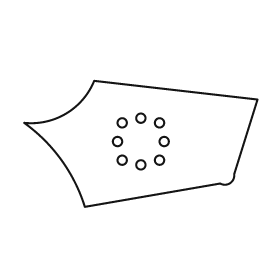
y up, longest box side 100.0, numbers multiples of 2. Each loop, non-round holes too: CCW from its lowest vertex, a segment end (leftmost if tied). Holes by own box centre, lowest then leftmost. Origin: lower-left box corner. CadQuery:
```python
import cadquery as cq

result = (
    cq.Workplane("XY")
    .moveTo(26.0, 0.0)
    .lineTo(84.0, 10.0)
    .threePointArc((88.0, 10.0), (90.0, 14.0))
    .lineTo(100.0, 46.0)
    .lineTo(30.0, 54.0)
    .threePointArc((18.0, 40.0), (0.0, 36.0))
    .threePointArc((16.0, 20.0), (26.0, 0.0))
    .close()
    .moveTo(50.0, 18.0)
    .circle(2.0)
    .moveTo(42.0, 20.0)
    .circle(2.0)
    .moveTo(58.0, 20.0)
    .circle(2.0)
    .moveTo(40.0, 28.0)
    .circle(2.0)
    .moveTo(60.0, 28.0)
    .circle(2.0)
    .moveTo(42.0, 36.0)
    .circle(2.0)
    .moveTo(58.0, 36.0)
    .circle(2.0)
    .moveTo(50.0, 38.0)
    .circle(2.0)
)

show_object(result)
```